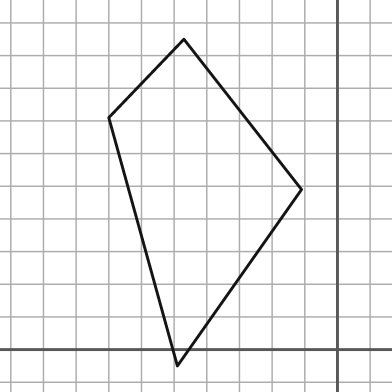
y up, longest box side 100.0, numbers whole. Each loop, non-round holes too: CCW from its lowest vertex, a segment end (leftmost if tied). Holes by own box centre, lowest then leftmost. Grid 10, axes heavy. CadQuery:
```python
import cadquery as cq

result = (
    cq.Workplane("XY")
    .moveTo(-49.0, -5.0)
    .lineTo(-11.0, 49.0)
    .lineTo(-47.0, 95.0)
    .lineTo(-70.0, 71.0)
    .close()
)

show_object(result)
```